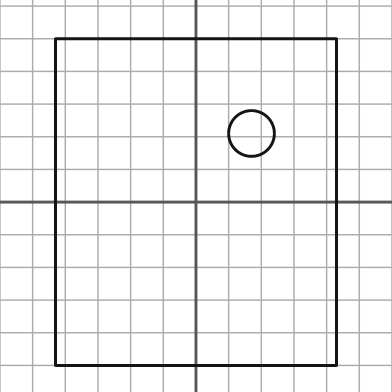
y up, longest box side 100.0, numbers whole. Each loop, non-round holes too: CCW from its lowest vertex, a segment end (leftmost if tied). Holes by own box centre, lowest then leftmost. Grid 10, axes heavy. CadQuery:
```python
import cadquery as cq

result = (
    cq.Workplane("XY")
    .moveTo(-43.0, -50.0)
    .lineTo(43.0, -50.0)
    .lineTo(43.0, 50.0)
    .lineTo(-43.0, 50.0)
    .close()
    .moveTo(17.0, 21.0)
    .circle(7.0)
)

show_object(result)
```